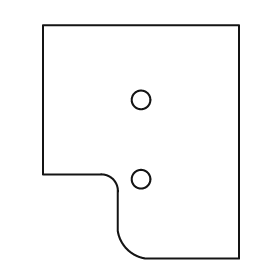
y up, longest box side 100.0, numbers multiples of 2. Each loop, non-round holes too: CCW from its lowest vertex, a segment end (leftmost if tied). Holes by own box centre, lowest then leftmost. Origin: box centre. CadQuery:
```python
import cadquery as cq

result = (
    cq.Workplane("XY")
    .moveTo(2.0, -50.0)
    .lineTo(42.0, -50.0)
    .lineTo(42.0, 50.0)
    .lineTo(-42.0, 50.0)
    .lineTo(-42.0, -14.0)
    .lineTo(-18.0, -14.0)
    .threePointArc((-12.0, -16.0), (-10.0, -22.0))
    .lineTo(-10.0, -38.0)
    .threePointArc((-6.0, -46.0), (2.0, -50.0))
    .close()
    .moveTo(0.0, -16.0)
    .circle(4.0)
    .moveTo(0.0, 18.0)
    .circle(4.0)
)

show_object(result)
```